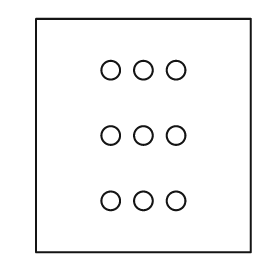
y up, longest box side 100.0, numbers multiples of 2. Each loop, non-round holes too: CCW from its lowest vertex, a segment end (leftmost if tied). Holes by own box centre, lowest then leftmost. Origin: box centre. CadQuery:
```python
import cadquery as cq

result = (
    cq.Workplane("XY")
    .moveTo(-46.0, -50.0)
    .lineTo(46.0, -50.0)
    .lineTo(46.0, 50.0)
    .lineTo(-46.0, 50.0)
    .close()
    .moveTo(-14.0, -28.0)
    .circle(4.0)
    .moveTo(0.0, -28.0)
    .circle(4.0)
    .moveTo(14.0, -28.0)
    .circle(4.0)
    .moveTo(-14.0, 0.0)
    .circle(4.0)
    .moveTo(0.0, 0.0)
    .circle(4.0)
    .moveTo(14.0, 0.0)
    .circle(4.0)
    .moveTo(-14.0, 28.0)
    .circle(4.0)
    .moveTo(0.0, 28.0)
    .circle(4.0)
    .moveTo(14.0, 28.0)
    .circle(4.0)
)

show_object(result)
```